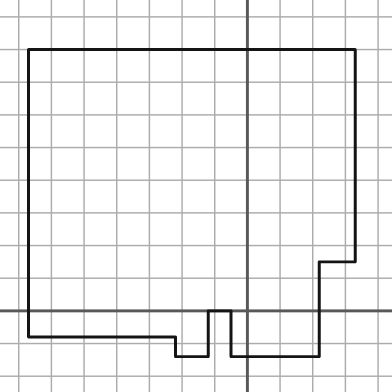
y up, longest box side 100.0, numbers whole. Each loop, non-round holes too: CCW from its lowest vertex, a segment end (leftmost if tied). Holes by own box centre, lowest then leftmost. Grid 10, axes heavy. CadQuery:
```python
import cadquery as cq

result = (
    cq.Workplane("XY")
    .moveTo(-22.0, -14.0)
    .lineTo(-12.0, -14.0)
    .lineTo(-12.0, 0.0)
    .lineTo(-5.0, 0.0)
    .lineTo(-5.0, -14.0)
    .lineTo(22.0, -14.0)
    .lineTo(22.0, 15.0)
    .lineTo(33.0, 15.0)
    .lineTo(33.0, 80.0)
    .lineTo(-67.0, 80.0)
    .lineTo(-67.0, -8.0)
    .lineTo(-22.0, -8.0)
    .close()
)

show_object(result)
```